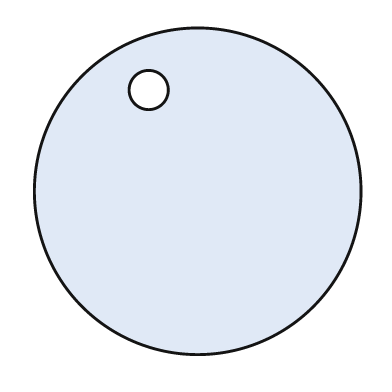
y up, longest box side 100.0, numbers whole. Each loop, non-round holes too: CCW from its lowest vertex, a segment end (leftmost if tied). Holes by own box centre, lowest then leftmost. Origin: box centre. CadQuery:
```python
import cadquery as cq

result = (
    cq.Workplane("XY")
    .moveTo(0.0, 0.0)
    .circle(50.0)
    .moveTo(-15.0, 31.0)
    .circle(6.0)
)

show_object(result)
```